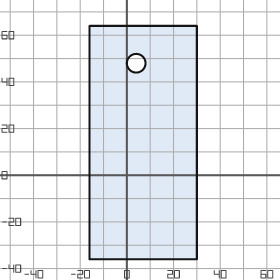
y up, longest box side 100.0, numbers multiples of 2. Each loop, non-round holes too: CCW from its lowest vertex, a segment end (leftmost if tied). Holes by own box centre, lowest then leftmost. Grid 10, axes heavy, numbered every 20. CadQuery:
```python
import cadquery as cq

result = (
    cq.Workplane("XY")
    .moveTo(-16.0, -36.0)
    .lineTo(30.0, -36.0)
    .lineTo(30.0, 64.0)
    .lineTo(-16.0, 64.0)
    .close()
    .moveTo(4.0, 48.0)
    .circle(4.0)
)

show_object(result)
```